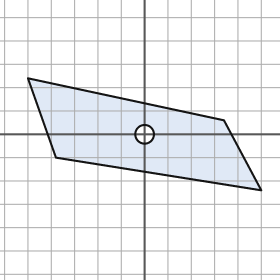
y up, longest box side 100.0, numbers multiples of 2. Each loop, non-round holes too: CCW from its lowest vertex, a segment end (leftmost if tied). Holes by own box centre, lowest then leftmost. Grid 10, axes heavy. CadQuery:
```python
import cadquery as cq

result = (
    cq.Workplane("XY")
    .moveTo(50.0, -24.0)
    .lineTo(34.0, 6.0)
    .lineTo(-50.0, 24.0)
    .lineTo(-38.0, -10.0)
    .close()
    .moveTo(0.0, 0.0)
    .circle(4.0)
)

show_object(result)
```